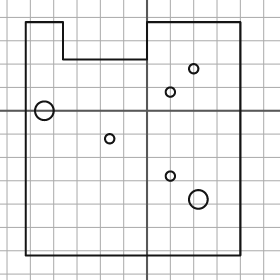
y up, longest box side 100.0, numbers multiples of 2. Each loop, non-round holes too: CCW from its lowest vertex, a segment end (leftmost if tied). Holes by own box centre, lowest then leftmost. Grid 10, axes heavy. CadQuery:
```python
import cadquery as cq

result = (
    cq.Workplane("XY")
    .moveTo(-52.0, -62.0)
    .lineTo(40.0, -62.0)
    .lineTo(40.0, 38.0)
    .lineTo(0.0, 38.0)
    .lineTo(0.0, 22.0)
    .lineTo(-36.0, 22.0)
    .lineTo(-36.0, 38.0)
    .lineTo(-52.0, 38.0)
    .close()
    .moveTo(22.0, -38.0)
    .circle(4.0)
    .moveTo(10.0, -28.0)
    .circle(2.0)
    .moveTo(-16.0, -12.0)
    .circle(2.0)
    .moveTo(-44.0, 0.0)
    .circle(4.0)
    .moveTo(10.0, 8.0)
    .circle(2.0)
    .moveTo(20.0, 18.0)
    .circle(2.0)
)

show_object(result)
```